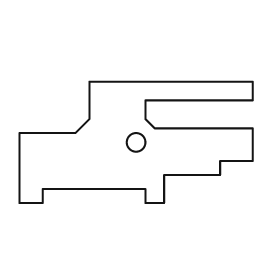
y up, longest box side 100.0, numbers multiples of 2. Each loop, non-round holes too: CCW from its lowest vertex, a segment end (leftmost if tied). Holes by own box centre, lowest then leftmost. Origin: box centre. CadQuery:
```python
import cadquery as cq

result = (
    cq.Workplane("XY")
    .moveTo(-50.0, -26.0)
    .lineTo(-40.0, -26.0)
    .lineTo(-40.0, -20.0)
    .lineTo(4.0, -20.0)
    .lineTo(4.0, -26.0)
    .lineTo(12.0, -26.0)
    .lineTo(12.0, -14.0)
    .lineTo(36.0, -14.0)
    .lineTo(36.0, -8.0)
    .lineTo(50.0, -8.0)
    .lineTo(50.0, 6.0)
    .lineTo(8.0, 6.0)
    .lineTo(4.0, 10.0)
    .lineTo(4.0, 18.0)
    .lineTo(50.0, 18.0)
    .lineTo(50.0, 26.0)
    .lineTo(-20.0, 26.0)
    .lineTo(-20.0, 10.0)
    .lineTo(-26.0, 4.0)
    .lineTo(-50.0, 4.0)
    .close()
    .moveTo(0.0, 0.0)
    .circle(4.0)
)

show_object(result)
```